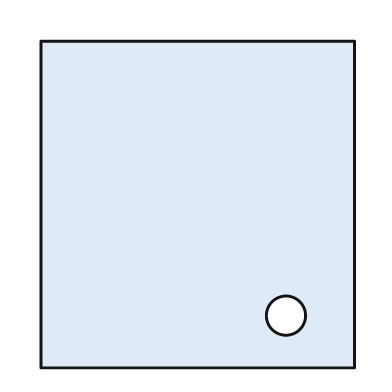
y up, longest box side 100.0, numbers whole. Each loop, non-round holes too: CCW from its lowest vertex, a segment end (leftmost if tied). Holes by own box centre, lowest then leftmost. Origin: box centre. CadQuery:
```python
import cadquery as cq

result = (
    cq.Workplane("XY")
    .moveTo(-48.0, -50.0)
    .lineTo(48.0, -50.0)
    .lineTo(48.0, 50.0)
    .lineTo(-48.0, 50.0)
    .close()
    .moveTo(27.0, -34.0)
    .circle(6.0)
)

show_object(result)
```